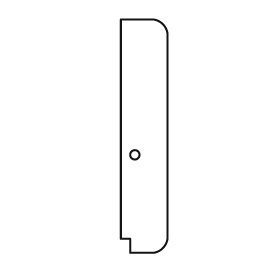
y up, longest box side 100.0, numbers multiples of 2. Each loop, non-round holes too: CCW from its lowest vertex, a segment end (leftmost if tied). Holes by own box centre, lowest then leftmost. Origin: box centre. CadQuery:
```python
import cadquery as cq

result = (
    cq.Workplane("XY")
    .moveTo(-6.0, -50.0)
    .lineTo(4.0, -50.0)
    .threePointArc((8.0, -48.0), (10.0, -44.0))
    .lineTo(10.0, 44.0)
    .threePointArc((8.0, 48.0), (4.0, 50.0))
    .lineTo(-10.0, 50.0)
    .lineTo(-10.0, -44.0)
    .lineTo(-6.0, -44.0)
    .close()
    .moveTo(-4.0, -8.0)
    .circle(2.0)
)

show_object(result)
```